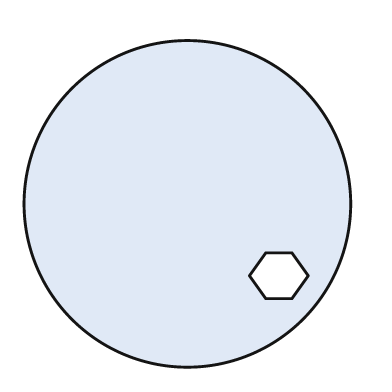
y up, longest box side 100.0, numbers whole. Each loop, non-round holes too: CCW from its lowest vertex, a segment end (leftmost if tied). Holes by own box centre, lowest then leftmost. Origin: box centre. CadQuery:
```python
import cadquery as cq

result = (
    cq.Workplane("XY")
    .moveTo(0.0, 0.0)
    .circle(50.0)
    .moveTo(24.0, -29.0)
    .lineTo(32.0, -29.0)
    .lineTo(37.0, -22.0)
    .lineTo(32.0, -15.0)
    .lineTo(24.0, -15.0)
    .lineTo(19.0, -22.0)
    .close()
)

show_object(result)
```